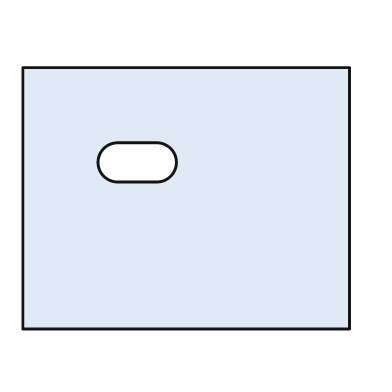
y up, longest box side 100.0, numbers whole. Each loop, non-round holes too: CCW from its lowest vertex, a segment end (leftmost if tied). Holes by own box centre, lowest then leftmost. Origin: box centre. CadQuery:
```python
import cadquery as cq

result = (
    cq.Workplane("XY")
    .moveTo(-50.0, -40.0)
    .lineTo(50.0, -40.0)
    .lineTo(50.0, 40.0)
    .lineTo(-50.0, 40.0)
    .close()
    .moveTo(-21.0, 5.0)
    .lineTo(-9.0, 5.0)
    .threePointArc((-3.0, 11.0), (-9.0, 17.0))
    .lineTo(-21.0, 17.0)
    .threePointArc((-27.0, 11.0), (-21.0, 5.0))
    .close()
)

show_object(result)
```